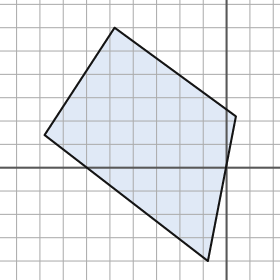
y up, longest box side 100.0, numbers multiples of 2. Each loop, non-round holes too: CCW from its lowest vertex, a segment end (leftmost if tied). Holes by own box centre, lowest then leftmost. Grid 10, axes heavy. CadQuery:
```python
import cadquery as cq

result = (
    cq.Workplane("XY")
    .moveTo(-8.0, -40.0)
    .lineTo(4.0, 22.0)
    .lineTo(-48.0, 60.0)
    .lineTo(-78.0, 14.0)
    .close()
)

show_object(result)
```